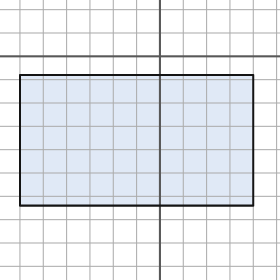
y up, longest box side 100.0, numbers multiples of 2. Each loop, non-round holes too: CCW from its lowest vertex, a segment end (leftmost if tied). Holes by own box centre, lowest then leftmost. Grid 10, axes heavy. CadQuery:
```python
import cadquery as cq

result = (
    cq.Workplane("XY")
    .moveTo(-60.0, -64.0)
    .lineTo(40.0, -64.0)
    .lineTo(40.0, -8.0)
    .lineTo(-60.0, -8.0)
    .close()
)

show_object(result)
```